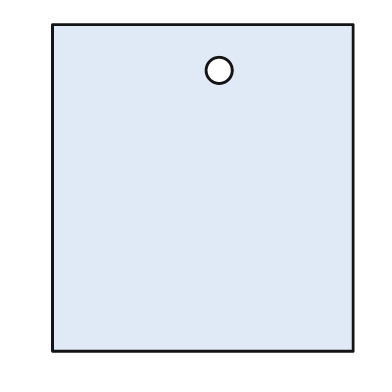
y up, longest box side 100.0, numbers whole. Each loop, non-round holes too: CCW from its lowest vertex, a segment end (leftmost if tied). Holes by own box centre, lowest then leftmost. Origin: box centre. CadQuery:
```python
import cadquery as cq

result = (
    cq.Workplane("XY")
    .moveTo(-46.0, -50.0)
    .lineTo(46.0, -50.0)
    .lineTo(46.0, 50.0)
    .lineTo(-46.0, 50.0)
    .close()
    .moveTo(5.0, 36.0)
    .circle(4.0)
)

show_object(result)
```